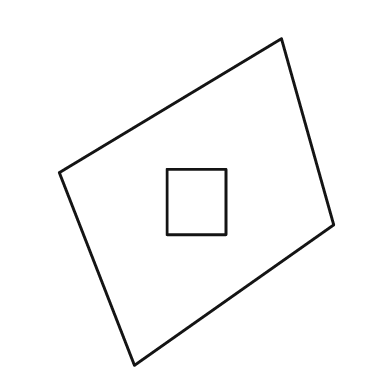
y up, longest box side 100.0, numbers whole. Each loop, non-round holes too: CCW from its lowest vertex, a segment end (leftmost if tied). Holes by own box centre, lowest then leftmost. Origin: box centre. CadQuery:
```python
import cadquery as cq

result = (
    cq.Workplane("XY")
    .moveTo(-19.0, -50.0)
    .lineTo(42.0, -7.0)
    .lineTo(26.0, 50.0)
    .lineTo(-42.0, 9.0)
    .close()
    .moveTo(-9.0, -10.0)
    .lineTo(9.0, -10.0)
    .lineTo(9.0, 10.0)
    .lineTo(-9.0, 10.0)
    .close()
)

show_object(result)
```